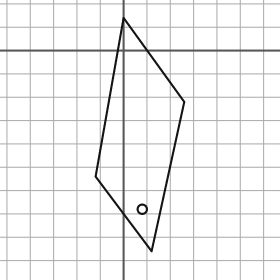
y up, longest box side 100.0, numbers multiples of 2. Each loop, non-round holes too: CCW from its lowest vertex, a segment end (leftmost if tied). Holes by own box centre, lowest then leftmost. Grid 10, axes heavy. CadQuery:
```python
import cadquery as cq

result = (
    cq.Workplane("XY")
    .moveTo(12.0, -86.0)
    .lineTo(26.0, -22.0)
    .lineTo(0.0, 14.0)
    .lineTo(-12.0, -54.0)
    .close()
    .moveTo(8.0, -68.0)
    .circle(2.0)
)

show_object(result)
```